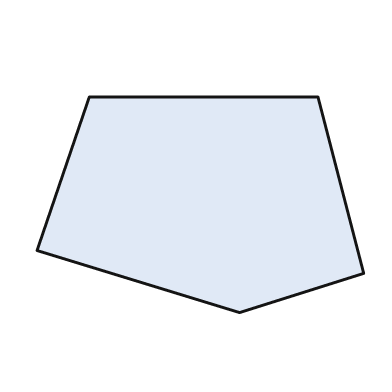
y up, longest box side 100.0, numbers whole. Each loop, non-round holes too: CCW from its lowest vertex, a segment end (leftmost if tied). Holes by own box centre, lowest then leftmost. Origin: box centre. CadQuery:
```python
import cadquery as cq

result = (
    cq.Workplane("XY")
    .moveTo(12.0, -33.0)
    .lineTo(50.0, -21.0)
    .lineTo(36.0, 33.0)
    .lineTo(-34.0, 33.0)
    .lineTo(-50.0, -14.0)
    .close()
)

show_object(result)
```